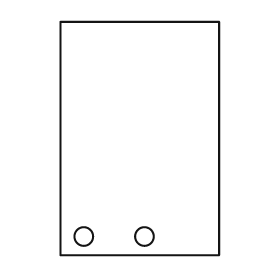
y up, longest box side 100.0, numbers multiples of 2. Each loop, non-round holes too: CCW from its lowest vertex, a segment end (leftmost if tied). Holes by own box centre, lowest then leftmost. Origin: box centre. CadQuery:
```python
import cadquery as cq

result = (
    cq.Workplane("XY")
    .moveTo(-34.0, -50.0)
    .lineTo(34.0, -50.0)
    .lineTo(34.0, 50.0)
    .lineTo(-34.0, 50.0)
    .close()
    .moveTo(-24.0, -42.0)
    .circle(4.0)
    .moveTo(2.0, -42.0)
    .circle(4.0)
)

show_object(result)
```